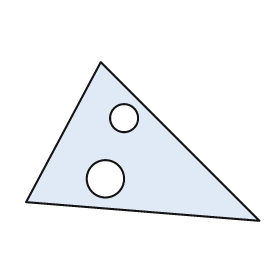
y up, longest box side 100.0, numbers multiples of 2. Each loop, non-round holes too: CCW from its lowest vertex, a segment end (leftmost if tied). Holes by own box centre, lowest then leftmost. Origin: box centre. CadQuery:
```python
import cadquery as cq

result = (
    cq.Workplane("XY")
    .moveTo(50.0, -34.0)
    .lineTo(-18.0, 34.0)
    .lineTo(-50.0, -26.0)
    .close()
    .moveTo(-16.0, -16.0)
    .circle(8.0)
    .moveTo(-8.0, 10.0)
    .circle(6.0)
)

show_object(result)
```